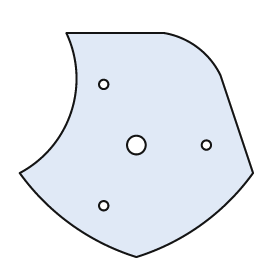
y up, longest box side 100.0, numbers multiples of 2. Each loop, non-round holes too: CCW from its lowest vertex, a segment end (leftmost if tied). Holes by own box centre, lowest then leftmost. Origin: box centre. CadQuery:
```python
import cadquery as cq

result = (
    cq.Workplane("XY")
    .moveTo(0.0, -48.0)
    .threePointArc((28.0, -34.0), (50.0, -12.0))
    .lineTo(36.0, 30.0)
    .threePointArc((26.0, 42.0), (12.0, 48.0))
    .lineTo(-30.0, 48.0)
    .threePointArc((-28.0, 14.0), (-50.0, -12.0))
    .threePointArc((-28.0, -34.0), (0.0, -48.0))
    .close()
    .moveTo(-14.0, -26.0)
    .circle(2.0)
    .moveTo(0.0, 0.0)
    .circle(4.0)
    .moveTo(30.0, 0.0)
    .circle(2.0)
    .moveTo(-14.0, 26.0)
    .circle(2.0)
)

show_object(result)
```